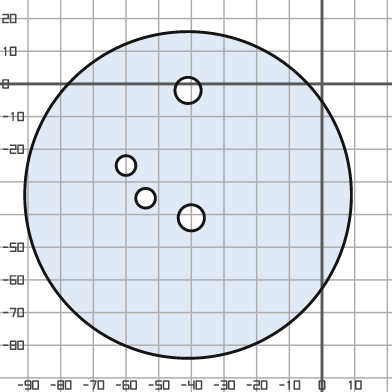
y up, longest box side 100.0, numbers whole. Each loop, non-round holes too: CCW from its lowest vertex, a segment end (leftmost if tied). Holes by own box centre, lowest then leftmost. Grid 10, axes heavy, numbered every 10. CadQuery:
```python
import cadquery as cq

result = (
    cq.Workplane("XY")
    .moveTo(-41.0, -34.0)
    .circle(50.0)
    .moveTo(-40.0, -41.0)
    .circle(4.0)
    .moveTo(-54.0, -35.0)
    .circle(3.0)
    .moveTo(-60.0, -25.0)
    .circle(3.0)
    .moveTo(-41.0, -2.0)
    .circle(4.0)
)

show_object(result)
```